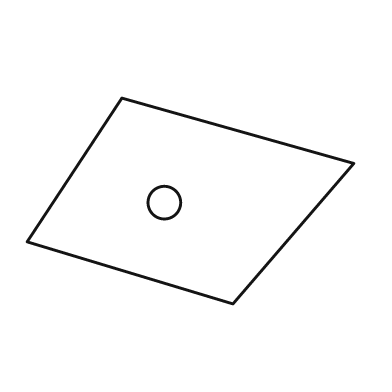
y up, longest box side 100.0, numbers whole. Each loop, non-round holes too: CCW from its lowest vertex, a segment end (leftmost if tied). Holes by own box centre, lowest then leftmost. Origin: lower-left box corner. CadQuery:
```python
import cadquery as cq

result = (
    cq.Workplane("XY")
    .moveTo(63.0, 0.0)
    .lineTo(100.0, 43.0)
    .lineTo(29.0, 63.0)
    .lineTo(0.0, 19.0)
    .close()
    .moveTo(42.0, 31.0)
    .circle(5.0)
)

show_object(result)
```